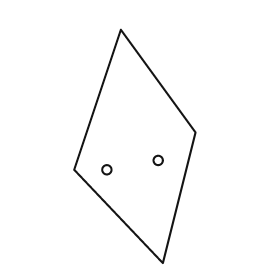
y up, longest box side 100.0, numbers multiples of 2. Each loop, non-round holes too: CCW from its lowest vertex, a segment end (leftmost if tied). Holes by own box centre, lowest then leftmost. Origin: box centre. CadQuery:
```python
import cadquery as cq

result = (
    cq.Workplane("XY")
    .moveTo(12.0, -50.0)
    .lineTo(26.0, 6.0)
    .lineTo(-6.0, 50.0)
    .lineTo(-26.0, -10.0)
    .close()
    .moveTo(-12.0, -10.0)
    .circle(2.0)
    .moveTo(10.0, -6.0)
    .circle(2.0)
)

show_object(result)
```